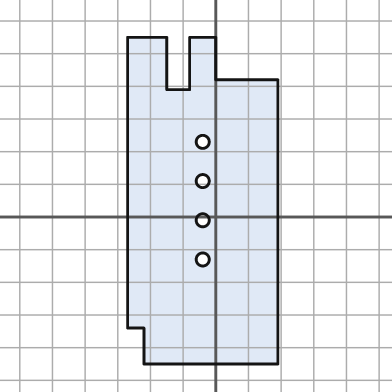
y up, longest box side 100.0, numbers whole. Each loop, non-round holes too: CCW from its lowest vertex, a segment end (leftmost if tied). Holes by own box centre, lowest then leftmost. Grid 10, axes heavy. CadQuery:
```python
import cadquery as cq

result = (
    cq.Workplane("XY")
    .moveTo(-22.0, -45.0)
    .lineTo(19.0, -45.0)
    .lineTo(19.0, 42.0)
    .lineTo(0.0, 42.0)
    .lineTo(0.0, 55.0)
    .lineTo(-8.0, 55.0)
    .lineTo(-8.0, 39.0)
    .lineTo(-15.0, 39.0)
    .lineTo(-15.0, 55.0)
    .lineTo(-27.0, 55.0)
    .lineTo(-27.0, -34.0)
    .lineTo(-22.0, -34.0)
    .close()
    .moveTo(-4.0, -13.0)
    .circle(2.0)
    .moveTo(-4.0, -1.0)
    .circle(2.0)
    .moveTo(-4.0, 11.0)
    .circle(2.0)
    .moveTo(-4.0, 23.0)
    .circle(2.0)
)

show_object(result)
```